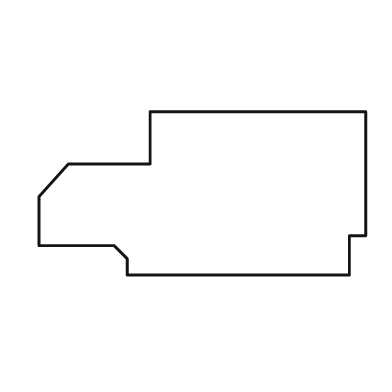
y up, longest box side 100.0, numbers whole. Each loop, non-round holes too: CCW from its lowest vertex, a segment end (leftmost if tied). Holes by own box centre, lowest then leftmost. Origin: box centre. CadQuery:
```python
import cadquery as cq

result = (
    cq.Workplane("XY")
    .moveTo(-23.0, -25.0)
    .lineTo(45.0, -25.0)
    .lineTo(45.0, -13.0)
    .lineTo(50.0, -13.0)
    .lineTo(50.0, 25.0)
    .lineTo(-16.0, 25.0)
    .lineTo(-16.0, 9.0)
    .lineTo(-41.0, 9.0)
    .lineTo(-50.0, -1.0)
    .lineTo(-50.0, -16.0)
    .lineTo(-27.0, -16.0)
    .lineTo(-23.0, -20.0)
    .close()
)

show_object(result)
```